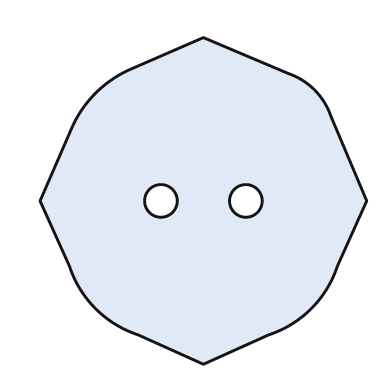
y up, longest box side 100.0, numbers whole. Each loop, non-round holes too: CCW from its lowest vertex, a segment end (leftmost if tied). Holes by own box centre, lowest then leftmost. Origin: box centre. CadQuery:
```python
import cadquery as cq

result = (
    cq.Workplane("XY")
    .moveTo(0.0, -50.0)
    .lineTo(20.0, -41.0)
    .threePointArc((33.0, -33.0), (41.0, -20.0))
    .lineTo(50.0, 0.0)
    .lineTo(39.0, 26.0)
    .threePointArc((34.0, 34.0), (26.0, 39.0))
    .lineTo(0.0, 50.0)
    .lineTo(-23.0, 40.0)
    .threePointArc((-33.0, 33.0), (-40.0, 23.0))
    .lineTo(-50.0, 0.0)
    .lineTo(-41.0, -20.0)
    .threePointArc((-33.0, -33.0), (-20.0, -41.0))
    .close()
    .moveTo(-13.0, 0.0)
    .circle(5.0)
    .moveTo(13.0, 0.0)
    .circle(5.0)
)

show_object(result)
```